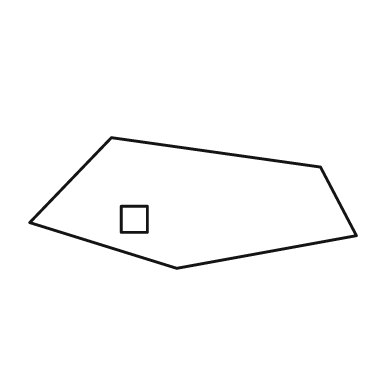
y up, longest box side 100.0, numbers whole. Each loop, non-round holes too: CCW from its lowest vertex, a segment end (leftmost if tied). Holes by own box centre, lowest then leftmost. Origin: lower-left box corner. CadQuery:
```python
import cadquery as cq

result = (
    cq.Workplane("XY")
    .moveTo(45.0, 0.0)
    .lineTo(100.0, 10.0)
    .lineTo(89.0, 31.0)
    .lineTo(25.0, 40.0)
    .lineTo(0.0, 14.0)
    .close()
    .moveTo(28.0, 11.0)
    .lineTo(36.0, 11.0)
    .lineTo(36.0, 19.0)
    .lineTo(28.0, 19.0)
    .close()
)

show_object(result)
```